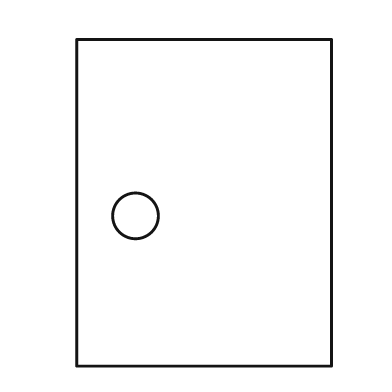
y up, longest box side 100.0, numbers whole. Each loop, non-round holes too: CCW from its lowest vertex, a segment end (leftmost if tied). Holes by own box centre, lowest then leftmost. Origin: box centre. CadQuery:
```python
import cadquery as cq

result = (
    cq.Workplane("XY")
    .moveTo(-39.0, -50.0)
    .lineTo(39.0, -50.0)
    .lineTo(39.0, 50.0)
    .lineTo(-39.0, 50.0)
    .close()
    .moveTo(-21.0, -4.0)
    .circle(7.0)
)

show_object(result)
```